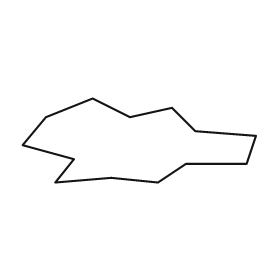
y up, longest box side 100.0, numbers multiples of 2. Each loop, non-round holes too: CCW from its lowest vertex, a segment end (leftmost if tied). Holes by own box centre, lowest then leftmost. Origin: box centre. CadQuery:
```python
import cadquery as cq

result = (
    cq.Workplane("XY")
    .moveTo(-36.0, -18.0)
    .lineTo(-12.0, -16.0)
    .lineTo(8.0, -18.0)
    .lineTo(20.0, -10.0)
    .lineTo(46.0, -10.0)
    .lineTo(50.0, 2.0)
    .lineTo(24.0, 4.0)
    .lineTo(14.0, 14.0)
    .lineTo(-4.0, 10.0)
    .lineTo(-20.0, 18.0)
    .lineTo(-40.0, 10.0)
    .lineTo(-50.0, -2.0)
    .lineTo(-28.0, -8.0)
    .close()
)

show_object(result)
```